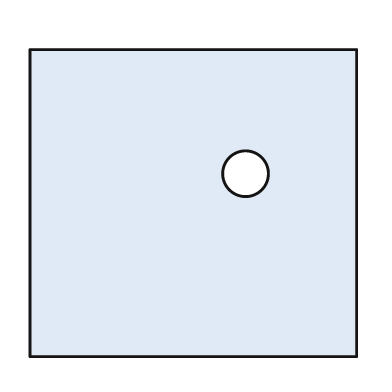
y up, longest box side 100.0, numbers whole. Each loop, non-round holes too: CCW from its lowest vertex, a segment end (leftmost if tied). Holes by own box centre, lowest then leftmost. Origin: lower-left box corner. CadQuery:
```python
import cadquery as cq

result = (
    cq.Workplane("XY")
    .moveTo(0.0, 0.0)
    .lineTo(100.0, 0.0)
    .lineTo(100.0, 94.0)
    .lineTo(0.0, 94.0)
    .close()
    .moveTo(66.0, 56.0)
    .circle(7.0)
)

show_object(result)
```